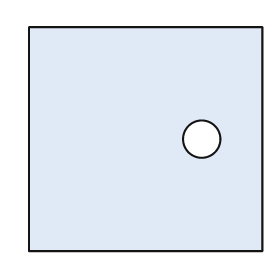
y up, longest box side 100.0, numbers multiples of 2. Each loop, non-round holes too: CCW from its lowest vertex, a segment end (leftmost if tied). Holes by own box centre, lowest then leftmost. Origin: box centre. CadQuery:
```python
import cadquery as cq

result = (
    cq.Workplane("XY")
    .moveTo(-50.0, -48.0)
    .lineTo(50.0, -48.0)
    .lineTo(50.0, 48.0)
    .lineTo(-50.0, 48.0)
    .close()
    .moveTo(24.0, 0.0)
    .circle(8.0)
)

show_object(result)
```